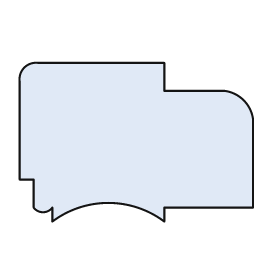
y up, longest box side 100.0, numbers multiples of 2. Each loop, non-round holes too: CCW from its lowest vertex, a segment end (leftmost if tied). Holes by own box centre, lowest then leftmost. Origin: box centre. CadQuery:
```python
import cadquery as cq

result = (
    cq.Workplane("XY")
    .moveTo(-36.0, -34.0)
    .threePointArc((-12.0, -26.0), (12.0, -34.0))
    .lineTo(12.0, -28.0)
    .lineTo(50.0, -28.0)
    .lineTo(50.0, 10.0)
    .threePointArc((46.0, 18.0), (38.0, 22.0))
    .lineTo(12.0, 22.0)
    .lineTo(12.0, 34.0)
    .lineTo(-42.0, 34.0)
    .threePointArc((-48.0, 32.0), (-50.0, 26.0))
    .lineTo(-50.0, -16.0)
    .lineTo(-44.0, -16.0)
    .lineTo(-44.0, -28.0)
    .threePointArc((-40.0, -30.0), (-36.0, -28.0))
    .close()
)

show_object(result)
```